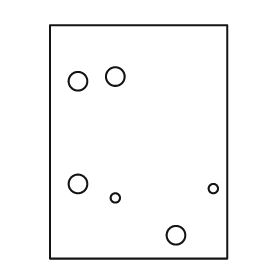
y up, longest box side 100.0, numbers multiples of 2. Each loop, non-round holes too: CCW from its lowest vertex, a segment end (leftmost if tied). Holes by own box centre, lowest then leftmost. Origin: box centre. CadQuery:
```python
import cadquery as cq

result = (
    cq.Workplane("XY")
    .moveTo(-38.0, -50.0)
    .lineTo(38.0, -50.0)
    .lineTo(38.0, 50.0)
    .lineTo(-38.0, 50.0)
    .close()
    .moveTo(16.0, -40.0)
    .circle(4.0)
    .moveTo(-10.0, -24.0)
    .circle(2.0)
    .moveTo(32.0, -20.0)
    .circle(2.0)
    .moveTo(-26.0, -18.0)
    .circle(4.0)
    .moveTo(-26.0, 26.0)
    .circle(4.0)
    .moveTo(-10.0, 28.0)
    .circle(4.0)
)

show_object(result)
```